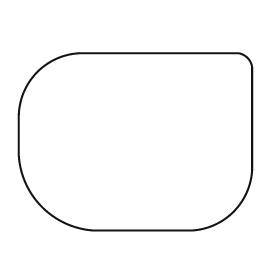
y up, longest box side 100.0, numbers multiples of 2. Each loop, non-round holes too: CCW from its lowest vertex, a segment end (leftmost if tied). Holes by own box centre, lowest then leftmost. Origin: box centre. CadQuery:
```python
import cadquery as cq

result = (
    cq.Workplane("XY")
    .moveTo(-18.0, -38.0)
    .lineTo(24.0, -38.0)
    .threePointArc((42.0, -30.0), (50.0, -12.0))
    .lineTo(50.0, 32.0)
    .threePointArc((48.0, 36.0), (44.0, 38.0))
    .lineTo(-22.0, 38.0)
    .threePointArc((-42.0, 30.0), (-50.0, 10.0))
    .lineTo(-50.0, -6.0)
    .threePointArc((-40.0, -28.0), (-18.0, -38.0))
    .close()
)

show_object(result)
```